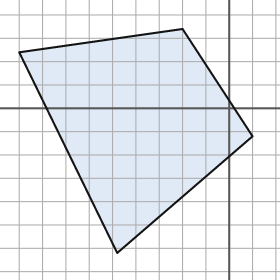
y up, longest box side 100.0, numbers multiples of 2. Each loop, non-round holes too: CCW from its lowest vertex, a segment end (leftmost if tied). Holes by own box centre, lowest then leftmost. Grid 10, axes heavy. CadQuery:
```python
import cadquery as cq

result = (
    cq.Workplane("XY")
    .moveTo(-48.0, -62.0)
    .lineTo(10.0, -12.0)
    .lineTo(-20.0, 34.0)
    .lineTo(-90.0, 24.0)
    .close()
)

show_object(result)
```